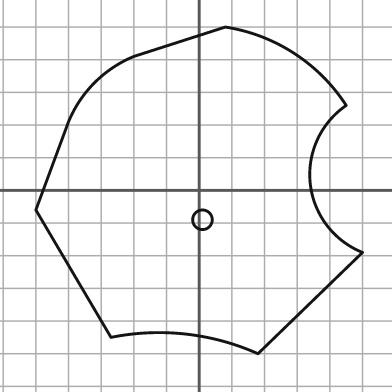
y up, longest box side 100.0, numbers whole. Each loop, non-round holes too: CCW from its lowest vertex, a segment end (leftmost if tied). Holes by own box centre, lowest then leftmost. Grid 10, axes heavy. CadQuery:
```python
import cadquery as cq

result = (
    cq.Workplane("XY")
    .moveTo(18.0, -50.0)
    .lineTo(50.0, -19.0)
    .threePointArc((34.0, 2.0), (45.0, 26.0))
    .threePointArc((29.0, 42.0), (8.0, 50.0))
    .lineTo(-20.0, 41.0)
    .threePointArc((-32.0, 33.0), (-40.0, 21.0))
    .lineTo(-50.0, -6.0)
    .lineTo(-27.0, -45.0)
    .threePointArc((-4.0, -44.0), (18.0, -50.0))
    .close()
    .moveTo(1.0, -9.0)
    .circle(3.0)
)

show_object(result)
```